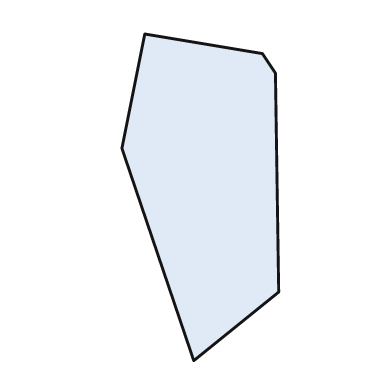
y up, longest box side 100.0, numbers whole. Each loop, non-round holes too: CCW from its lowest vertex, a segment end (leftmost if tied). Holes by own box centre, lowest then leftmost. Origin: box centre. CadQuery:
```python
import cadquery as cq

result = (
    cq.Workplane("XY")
    .moveTo(-2.0, -50.0)
    .lineTo(24.0, -29.0)
    .lineTo(23.0, 38.0)
    .lineTo(19.0, 44.0)
    .lineTo(-17.0, 50.0)
    .lineTo(-24.0, 15.0)
    .close()
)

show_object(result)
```